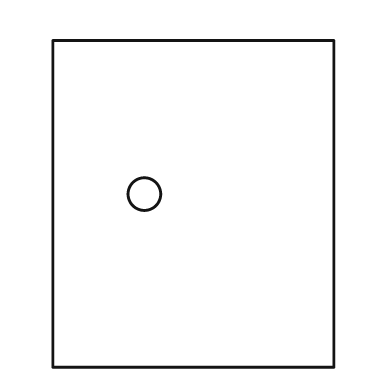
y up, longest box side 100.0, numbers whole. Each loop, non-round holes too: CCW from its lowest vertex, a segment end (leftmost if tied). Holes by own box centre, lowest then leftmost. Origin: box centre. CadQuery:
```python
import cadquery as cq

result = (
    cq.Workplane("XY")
    .moveTo(-43.0, -50.0)
    .lineTo(43.0, -50.0)
    .lineTo(43.0, 50.0)
    .lineTo(-43.0, 50.0)
    .close()
    .moveTo(-15.0, 3.0)
    .circle(5.0)
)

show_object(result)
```